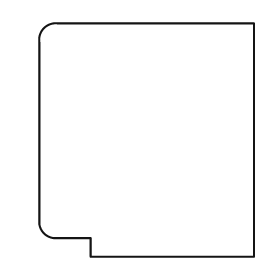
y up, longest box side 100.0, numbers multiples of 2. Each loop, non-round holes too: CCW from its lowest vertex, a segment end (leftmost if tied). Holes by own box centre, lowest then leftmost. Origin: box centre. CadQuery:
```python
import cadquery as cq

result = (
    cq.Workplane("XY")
    .moveTo(-24.0, -50.0)
    .lineTo(46.0, -50.0)
    .lineTo(46.0, 50.0)
    .lineTo(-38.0, 50.0)
    .threePointArc((-44.0, 48.0), (-46.0, 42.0))
    .lineTo(-46.0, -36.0)
    .threePointArc((-44.0, -40.0), (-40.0, -42.0))
    .lineTo(-24.0, -42.0)
    .close()
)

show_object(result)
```